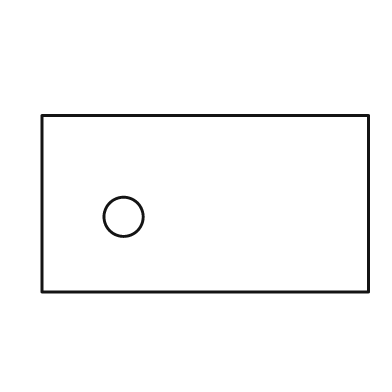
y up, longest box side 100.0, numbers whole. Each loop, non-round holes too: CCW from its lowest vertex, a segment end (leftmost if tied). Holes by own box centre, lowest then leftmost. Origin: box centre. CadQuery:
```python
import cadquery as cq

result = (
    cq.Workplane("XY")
    .moveTo(-50.0, -27.0)
    .lineTo(50.0, -27.0)
    .lineTo(50.0, 27.0)
    .lineTo(-50.0, 27.0)
    .close()
    .moveTo(-25.0, -4.0)
    .circle(6.0)
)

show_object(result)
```